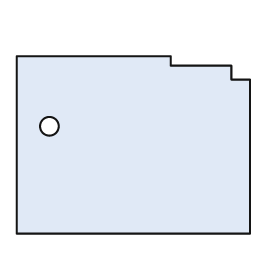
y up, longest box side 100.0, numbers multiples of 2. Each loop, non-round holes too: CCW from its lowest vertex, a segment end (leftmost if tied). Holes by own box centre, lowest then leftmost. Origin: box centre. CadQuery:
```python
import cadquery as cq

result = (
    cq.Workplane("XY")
    .moveTo(-50.0, -38.0)
    .lineTo(50.0, -38.0)
    .lineTo(50.0, 28.0)
    .lineTo(42.0, 28.0)
    .lineTo(42.0, 34.0)
    .lineTo(16.0, 34.0)
    .lineTo(16.0, 38.0)
    .lineTo(-50.0, 38.0)
    .close()
    .moveTo(-36.0, 8.0)
    .circle(4.0)
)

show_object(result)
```